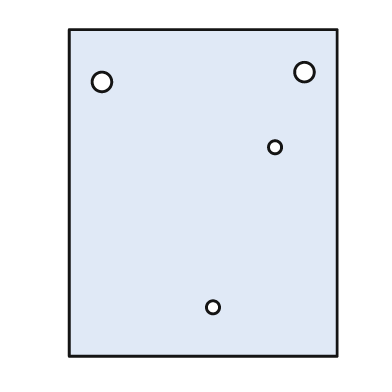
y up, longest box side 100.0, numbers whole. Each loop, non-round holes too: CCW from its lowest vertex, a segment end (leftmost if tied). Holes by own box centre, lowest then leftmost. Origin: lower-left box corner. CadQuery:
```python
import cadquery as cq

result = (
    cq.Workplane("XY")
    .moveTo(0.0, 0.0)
    .lineTo(82.0, 0.0)
    .lineTo(82.0, 100.0)
    .lineTo(0.0, 100.0)
    .close()
    .moveTo(44.0, 15.0)
    .circle(2.0)
    .moveTo(63.0, 64.0)
    .circle(2.0)
    .moveTo(10.0, 84.0)
    .circle(3.0)
    .moveTo(72.0, 87.0)
    .circle(3.0)
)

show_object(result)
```